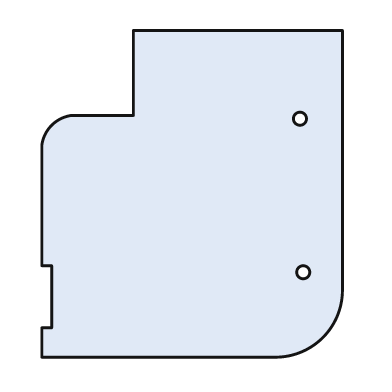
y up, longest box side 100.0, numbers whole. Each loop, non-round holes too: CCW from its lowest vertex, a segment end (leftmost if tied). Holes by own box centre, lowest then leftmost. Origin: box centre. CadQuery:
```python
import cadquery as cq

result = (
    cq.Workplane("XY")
    .moveTo(-46.0, -50.0)
    .lineTo(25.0, -50.0)
    .threePointArc((40.0, -44.0), (46.0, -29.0))
    .lineTo(46.0, 50.0)
    .lineTo(-18.0, 50.0)
    .lineTo(-18.0, 24.0)
    .lineTo(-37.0, 24.0)
    .threePointArc((-43.0, 21.0), (-46.0, 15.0))
    .lineTo(-46.0, -22.0)
    .lineTo(-43.0, -22.0)
    .lineTo(-43.0, -41.0)
    .lineTo(-46.0, -41.0)
    .close()
    .moveTo(34.0, -24.0)
    .circle(2.0)
    .moveTo(33.0, 23.0)
    .circle(2.0)
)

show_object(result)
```